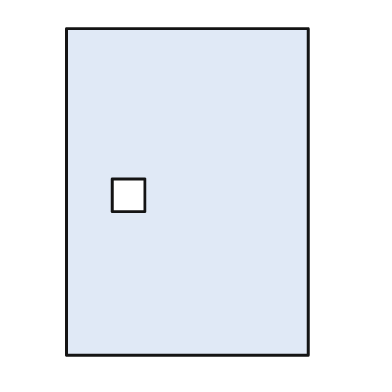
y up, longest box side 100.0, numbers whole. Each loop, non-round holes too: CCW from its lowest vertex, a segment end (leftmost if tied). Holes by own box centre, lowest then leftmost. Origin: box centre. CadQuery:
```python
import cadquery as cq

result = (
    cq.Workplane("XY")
    .moveTo(-37.0, -50.0)
    .lineTo(37.0, -50.0)
    .lineTo(37.0, 50.0)
    .lineTo(-37.0, 50.0)
    .close()
    .moveTo(-23.0, -6.0)
    .lineTo(-13.0, -6.0)
    .lineTo(-13.0, 4.0)
    .lineTo(-23.0, 4.0)
    .close()
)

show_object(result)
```